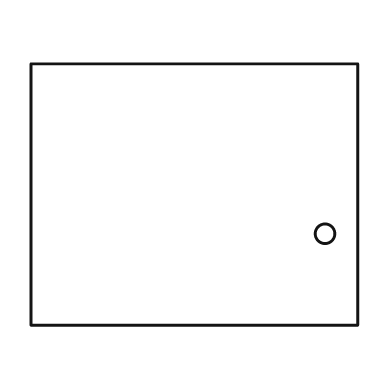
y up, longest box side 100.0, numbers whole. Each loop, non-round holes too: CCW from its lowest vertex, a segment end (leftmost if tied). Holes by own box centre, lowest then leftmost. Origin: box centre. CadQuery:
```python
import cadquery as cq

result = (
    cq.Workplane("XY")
    .moveTo(-50.0, -40.0)
    .lineTo(50.0, -40.0)
    .lineTo(50.0, 40.0)
    .lineTo(-50.0, 40.0)
    .close()
    .moveTo(40.0, -12.0)
    .circle(3.0)
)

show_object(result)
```